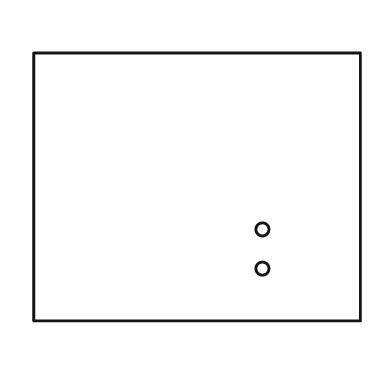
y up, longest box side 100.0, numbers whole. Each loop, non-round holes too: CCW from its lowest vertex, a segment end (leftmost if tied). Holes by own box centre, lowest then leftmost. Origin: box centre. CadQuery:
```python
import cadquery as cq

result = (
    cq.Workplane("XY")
    .moveTo(-50.0, -41.0)
    .lineTo(50.0, -41.0)
    .lineTo(50.0, 41.0)
    .lineTo(-50.0, 41.0)
    .close()
    .moveTo(20.0, -25.0)
    .circle(2.0)
    .moveTo(20.0, -13.0)
    .circle(2.0)
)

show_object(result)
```